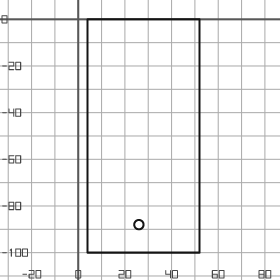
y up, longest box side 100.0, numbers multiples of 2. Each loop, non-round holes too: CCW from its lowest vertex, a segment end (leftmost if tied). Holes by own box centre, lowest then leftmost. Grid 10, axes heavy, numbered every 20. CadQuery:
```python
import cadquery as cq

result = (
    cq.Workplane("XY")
    .moveTo(4.0, -100.0)
    .lineTo(52.0, -100.0)
    .lineTo(52.0, 0.0)
    .lineTo(4.0, 0.0)
    .close()
    .moveTo(26.0, -88.0)
    .circle(2.0)
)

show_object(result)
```